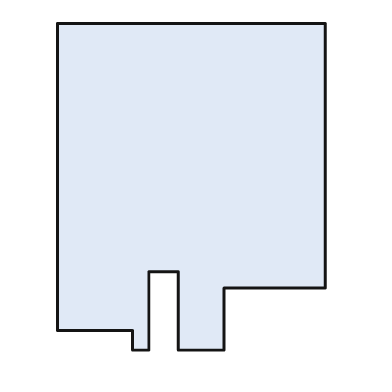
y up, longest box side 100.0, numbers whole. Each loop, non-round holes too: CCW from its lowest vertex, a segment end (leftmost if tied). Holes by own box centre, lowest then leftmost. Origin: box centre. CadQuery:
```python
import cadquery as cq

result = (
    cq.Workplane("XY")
    .moveTo(-18.0, -50.0)
    .lineTo(-13.0, -50.0)
    .lineTo(-13.0, -26.0)
    .lineTo(-4.0, -26.0)
    .lineTo(-4.0, -50.0)
    .lineTo(10.0, -50.0)
    .lineTo(10.0, -31.0)
    .lineTo(41.0, -31.0)
    .lineTo(41.0, 50.0)
    .lineTo(-41.0, 50.0)
    .lineTo(-41.0, -44.0)
    .lineTo(-18.0, -44.0)
    .close()
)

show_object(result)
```